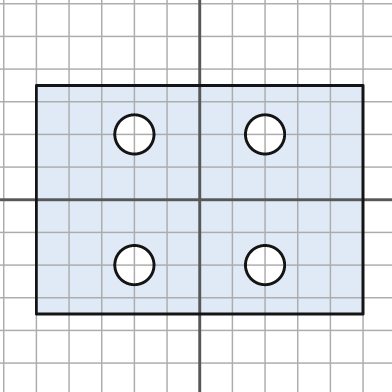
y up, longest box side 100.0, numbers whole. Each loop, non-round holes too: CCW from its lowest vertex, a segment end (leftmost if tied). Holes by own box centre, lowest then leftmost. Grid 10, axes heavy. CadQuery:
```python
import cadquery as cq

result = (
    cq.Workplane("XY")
    .moveTo(-50.0, -35.0)
    .lineTo(50.0, -35.0)
    .lineTo(50.0, 35.0)
    .lineTo(-50.0, 35.0)
    .close()
    .moveTo(-20.0, -20.0)
    .circle(6.0)
    .moveTo(20.0, -20.0)
    .circle(6.0)
    .moveTo(-20.0, 20.0)
    .circle(6.0)
    .moveTo(20.0, 20.0)
    .circle(6.0)
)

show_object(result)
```